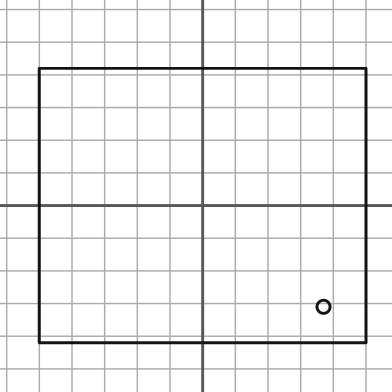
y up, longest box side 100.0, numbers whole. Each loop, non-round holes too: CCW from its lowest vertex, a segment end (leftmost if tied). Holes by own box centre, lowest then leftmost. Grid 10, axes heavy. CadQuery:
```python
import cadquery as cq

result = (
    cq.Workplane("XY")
    .moveTo(-50.0, -42.0)
    .lineTo(50.0, -42.0)
    .lineTo(50.0, 42.0)
    .lineTo(-50.0, 42.0)
    .close()
    .moveTo(37.0, -31.0)
    .circle(2.0)
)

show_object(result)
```